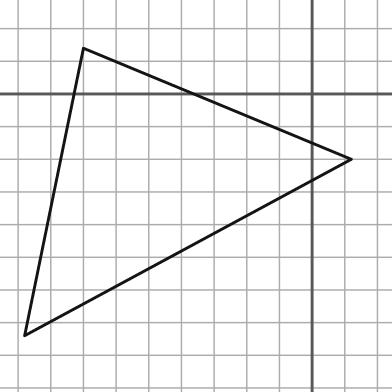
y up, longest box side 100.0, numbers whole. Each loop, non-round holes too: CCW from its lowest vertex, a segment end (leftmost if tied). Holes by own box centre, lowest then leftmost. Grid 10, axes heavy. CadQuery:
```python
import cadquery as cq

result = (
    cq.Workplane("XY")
    .moveTo(-88.0, -74.0)
    .lineTo(12.0, -20.0)
    .lineTo(-70.0, 14.0)
    .close()
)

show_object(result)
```